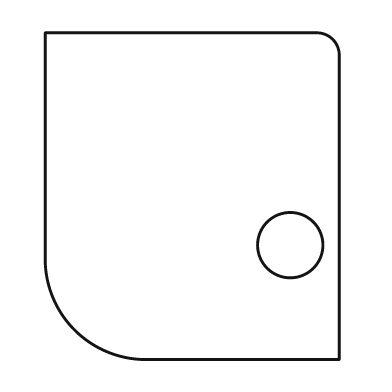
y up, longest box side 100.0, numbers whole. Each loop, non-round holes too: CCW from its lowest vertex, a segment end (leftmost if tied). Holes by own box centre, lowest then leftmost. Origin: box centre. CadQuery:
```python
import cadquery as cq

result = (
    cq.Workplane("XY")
    .moveTo(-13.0, -50.0)
    .lineTo(45.0, -50.0)
    .lineTo(45.0, 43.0)
    .threePointArc((43.0, 48.0), (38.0, 50.0))
    .lineTo(-45.0, 50.0)
    .lineTo(-45.0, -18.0)
    .threePointArc((-36.0, -41.0), (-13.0, -50.0))
    .close()
    .moveTo(30.0, -15.0)
    .circle(10.0)
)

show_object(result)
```